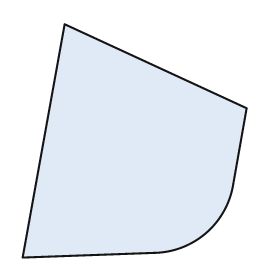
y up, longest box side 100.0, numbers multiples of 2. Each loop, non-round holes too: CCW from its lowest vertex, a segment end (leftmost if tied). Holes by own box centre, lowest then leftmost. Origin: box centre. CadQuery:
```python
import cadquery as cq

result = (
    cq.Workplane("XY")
    .moveTo(-48.0, -50.0)
    .lineTo(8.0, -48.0)
    .threePointArc((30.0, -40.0), (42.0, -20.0))
    .lineTo(48.0, 14.0)
    .lineTo(-30.0, 50.0)
    .close()
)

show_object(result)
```